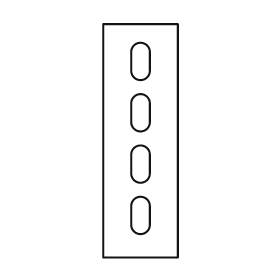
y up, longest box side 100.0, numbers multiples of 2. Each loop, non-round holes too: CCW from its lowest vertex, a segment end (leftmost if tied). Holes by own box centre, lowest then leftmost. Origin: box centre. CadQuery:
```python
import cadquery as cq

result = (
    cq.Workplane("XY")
    .moveTo(-16.0, -50.0)
    .lineTo(16.0, -50.0)
    .lineTo(16.0, 50.0)
    .lineTo(-16.0, 50.0)
    .close()
    .moveTo(-4.0, -36.0)
    .threePointArc((0.0, -40.0), (4.0, -36.0))
    .lineTo(4.0, -28.0)
    .threePointArc((0.0, -24.0), (-4.0, -28.0))
    .close()
    .moveTo(-4.0, -14.0)
    .threePointArc((0.0, -18.0), (4.0, -14.0))
    .lineTo(4.0, -6.0)
    .threePointArc((0.0, -2.0), (-4.0, -6.0))
    .close()
    .moveTo(-4.0, 8.0)
    .threePointArc((0.0, 4.0), (4.0, 8.0))
    .lineTo(4.0, 16.0)
    .threePointArc((0.0, 20.0), (-4.0, 16.0))
    .close()
    .moveTo(-4.0, 30.0)
    .threePointArc((0.0, 26.0), (4.0, 30.0))
    .lineTo(4.0, 38.0)
    .threePointArc((0.0, 42.0), (-4.0, 38.0))
    .close()
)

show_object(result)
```